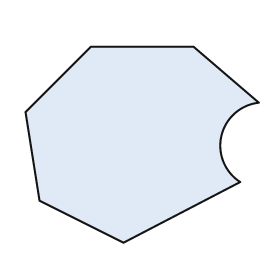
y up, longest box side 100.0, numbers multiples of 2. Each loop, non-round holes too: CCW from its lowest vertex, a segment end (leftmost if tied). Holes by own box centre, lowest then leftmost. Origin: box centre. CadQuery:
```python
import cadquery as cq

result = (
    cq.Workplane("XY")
    .moveTo(-8.0, -42.0)
    .lineTo(42.0, -16.0)
    .threePointArc((34.0, 4.0), (50.0, 18.0))
    .lineTo(22.0, 42.0)
    .lineTo(-22.0, 42.0)
    .lineTo(-50.0, 14.0)
    .lineTo(-44.0, -24.0)
    .close()
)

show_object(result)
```